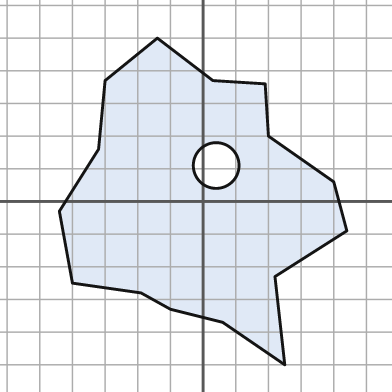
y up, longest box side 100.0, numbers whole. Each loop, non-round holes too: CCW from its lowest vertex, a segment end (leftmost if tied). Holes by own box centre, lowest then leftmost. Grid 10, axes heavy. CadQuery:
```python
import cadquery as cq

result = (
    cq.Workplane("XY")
    .moveTo(25.0, -50.0)
    .lineTo(22.0, -23.0)
    .lineTo(44.0, -9.0)
    .lineTo(40.0, 6.0)
    .lineTo(20.0, 20.0)
    .lineTo(19.0, 36.0)
    .lineTo(3.0, 37.0)
    .lineTo(-14.0, 50.0)
    .lineTo(-30.0, 37.0)
    .lineTo(-32.0, 16.0)
    .lineTo(-44.0, -3.0)
    .lineTo(-40.0, -25.0)
    .lineTo(-19.0, -28.0)
    .lineTo(-10.0, -33.0)
    .lineTo(6.0, -37.0)
    .close()
    .moveTo(4.0, 11.0)
    .circle(7.0)
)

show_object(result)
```